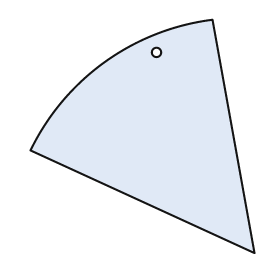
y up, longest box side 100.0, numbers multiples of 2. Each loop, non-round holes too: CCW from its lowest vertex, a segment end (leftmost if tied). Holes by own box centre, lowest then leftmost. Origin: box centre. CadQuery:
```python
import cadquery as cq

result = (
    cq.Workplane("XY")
    .moveTo(48.0, -50.0)
    .lineTo(30.0, 50.0)
    .threePointArc((-16.0, 32.0), (-48.0, -6.0))
    .close()
    .moveTo(6.0, 36.0)
    .circle(2.0)
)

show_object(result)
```